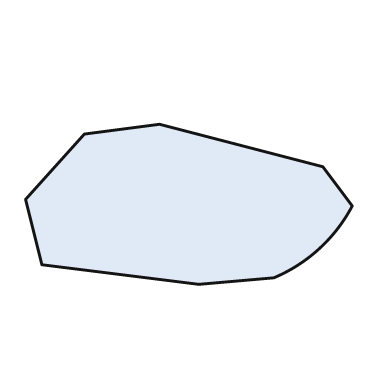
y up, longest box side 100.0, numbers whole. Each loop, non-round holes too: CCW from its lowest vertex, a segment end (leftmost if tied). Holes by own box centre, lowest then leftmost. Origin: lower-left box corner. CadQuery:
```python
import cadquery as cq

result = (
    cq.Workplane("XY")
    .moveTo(53.0, 0.0)
    .lineTo(76.0, 2.0)
    .threePointArc((90.0, 11.0), (100.0, 24.0))
    .lineTo(91.0, 36.0)
    .lineTo(41.0, 49.0)
    .lineTo(18.0, 46.0)
    .lineTo(0.0, 26.0)
    .lineTo(5.0, 6.0)
    .close()
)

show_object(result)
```